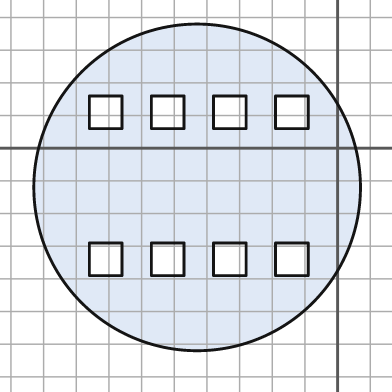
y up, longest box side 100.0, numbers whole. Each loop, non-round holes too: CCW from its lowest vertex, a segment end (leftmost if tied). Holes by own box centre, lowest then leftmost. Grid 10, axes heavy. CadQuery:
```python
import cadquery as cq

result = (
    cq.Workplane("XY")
    .moveTo(-43.0, -12.0)
    .circle(50.0)
    .moveTo(-76.0, -39.0)
    .lineTo(-66.0, -39.0)
    .lineTo(-66.0, -29.0)
    .lineTo(-76.0, -29.0)
    .close()
    .moveTo(-57.0, -39.0)
    .lineTo(-47.0, -39.0)
    .lineTo(-47.0, -29.0)
    .lineTo(-57.0, -29.0)
    .close()
    .moveTo(-38.0, -39.0)
    .lineTo(-28.0, -39.0)
    .lineTo(-28.0, -29.0)
    .lineTo(-38.0, -29.0)
    .close()
    .moveTo(-19.0, -39.0)
    .lineTo(-9.0, -39.0)
    .lineTo(-9.0, -29.0)
    .lineTo(-19.0, -29.0)
    .close()
    .moveTo(-76.0, 6.0)
    .lineTo(-66.0, 6.0)
    .lineTo(-66.0, 16.0)
    .lineTo(-76.0, 16.0)
    .close()
    .moveTo(-57.0, 6.0)
    .lineTo(-47.0, 6.0)
    .lineTo(-47.0, 16.0)
    .lineTo(-57.0, 16.0)
    .close()
    .moveTo(-38.0, 6.0)
    .lineTo(-28.0, 6.0)
    .lineTo(-28.0, 16.0)
    .lineTo(-38.0, 16.0)
    .close()
    .moveTo(-19.0, 6.0)
    .lineTo(-9.0, 6.0)
    .lineTo(-9.0, 16.0)
    .lineTo(-19.0, 16.0)
    .close()
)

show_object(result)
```